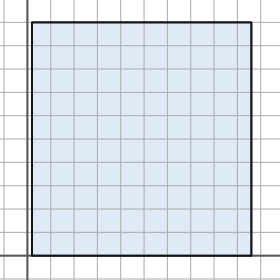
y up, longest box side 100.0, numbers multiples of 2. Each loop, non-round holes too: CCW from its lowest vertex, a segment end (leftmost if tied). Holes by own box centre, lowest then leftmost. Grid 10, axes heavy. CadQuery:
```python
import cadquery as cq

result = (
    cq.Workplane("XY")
    .moveTo(2.0, 0.0)
    .lineTo(96.0, 0.0)
    .lineTo(96.0, 100.0)
    .lineTo(2.0, 100.0)
    .close()
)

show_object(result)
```